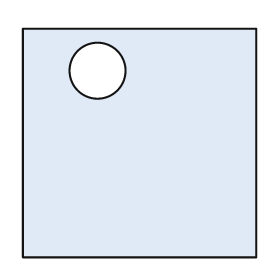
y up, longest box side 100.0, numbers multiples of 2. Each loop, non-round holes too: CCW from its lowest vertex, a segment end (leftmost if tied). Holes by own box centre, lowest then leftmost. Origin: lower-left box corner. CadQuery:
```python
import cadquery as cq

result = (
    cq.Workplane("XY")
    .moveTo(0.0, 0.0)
    .lineTo(100.0, 0.0)
    .lineTo(100.0, 98.0)
    .lineTo(0.0, 98.0)
    .close()
    .moveTo(32.0, 80.0)
    .circle(12.0)
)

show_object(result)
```